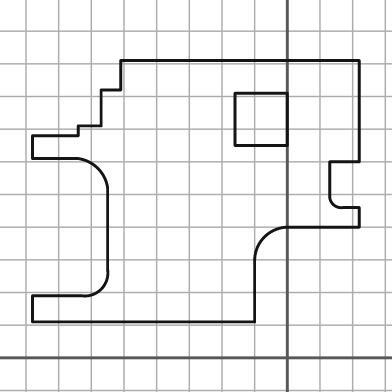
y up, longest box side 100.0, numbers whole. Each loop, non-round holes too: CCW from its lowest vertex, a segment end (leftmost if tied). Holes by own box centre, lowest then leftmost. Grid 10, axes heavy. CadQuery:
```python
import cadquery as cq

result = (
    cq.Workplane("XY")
    .moveTo(-78.0, 11.0)
    .lineTo(-10.0, 11.0)
    .lineTo(-10.0, 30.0)
    .threePointArc((-7.0, 37.0), (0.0, 40.0))
    .lineTo(22.0, 40.0)
    .lineTo(22.0, 46.0)
    .lineTo(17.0, 46.0)
    .threePointArc((14.0, 47.0), (13.0, 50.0))
    .lineTo(13.0, 60.0)
    .lineTo(22.0, 60.0)
    .lineTo(22.0, 91.0)
    .lineTo(-51.0, 91.0)
    .lineTo(-51.0, 82.0)
    .lineTo(-57.0, 82.0)
    .lineTo(-57.0, 71.0)
    .lineTo(-64.0, 71.0)
    .lineTo(-64.0, 68.0)
    .lineTo(-78.0, 68.0)
    .lineTo(-78.0, 61.0)
    .lineTo(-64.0, 61.0)
    .threePointArc((-58.0, 58.0), (-55.0, 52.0))
    .lineTo(-55.0, 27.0)
    .threePointArc((-57.0, 21.0), (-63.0, 19.0))
    .lineTo(-78.0, 19.0)
    .close()
    .moveTo(-16.0, 65.0)
    .lineTo(0.0, 65.0)
    .lineTo(0.0, 81.0)
    .lineTo(-16.0, 81.0)
    .close()
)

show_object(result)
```